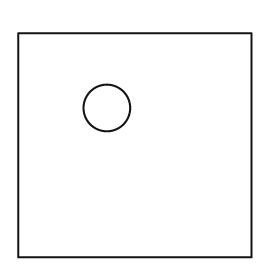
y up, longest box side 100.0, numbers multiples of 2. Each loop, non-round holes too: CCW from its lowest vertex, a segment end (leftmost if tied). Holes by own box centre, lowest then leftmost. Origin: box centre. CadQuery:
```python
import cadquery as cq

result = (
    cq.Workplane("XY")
    .moveTo(-50.0, -48.0)
    .lineTo(50.0, -48.0)
    .lineTo(50.0, 48.0)
    .lineTo(-50.0, 48.0)
    .close()
    .moveTo(-12.0, 16.0)
    .circle(10.0)
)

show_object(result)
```